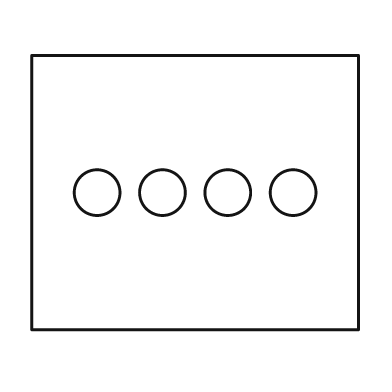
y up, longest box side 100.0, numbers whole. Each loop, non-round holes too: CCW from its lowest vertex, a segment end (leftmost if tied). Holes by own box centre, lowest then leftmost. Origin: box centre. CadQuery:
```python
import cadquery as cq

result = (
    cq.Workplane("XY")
    .moveTo(-50.0, -42.0)
    .lineTo(50.0, -42.0)
    .lineTo(50.0, 42.0)
    .lineTo(-50.0, 42.0)
    .close()
    .moveTo(-30.0, 0.0)
    .circle(7.0)
    .moveTo(-10.0, 0.0)
    .circle(7.0)
    .moveTo(10.0, 0.0)
    .circle(7.0)
    .moveTo(30.0, 0.0)
    .circle(7.0)
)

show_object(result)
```